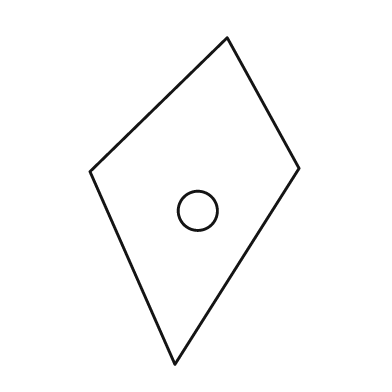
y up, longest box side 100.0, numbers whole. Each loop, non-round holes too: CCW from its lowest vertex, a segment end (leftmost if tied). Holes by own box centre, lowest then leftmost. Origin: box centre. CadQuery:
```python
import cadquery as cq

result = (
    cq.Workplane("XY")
    .moveTo(-6.0, -50.0)
    .lineTo(32.0, 10.0)
    .lineTo(10.0, 50.0)
    .lineTo(-32.0, 9.0)
    .close()
    .moveTo(1.0, -3.0)
    .circle(6.0)
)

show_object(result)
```